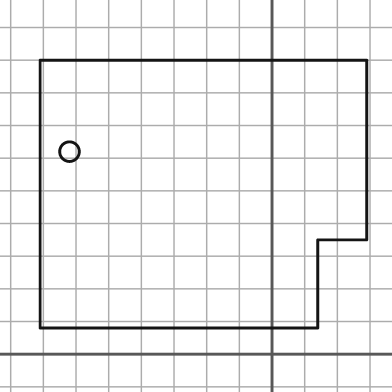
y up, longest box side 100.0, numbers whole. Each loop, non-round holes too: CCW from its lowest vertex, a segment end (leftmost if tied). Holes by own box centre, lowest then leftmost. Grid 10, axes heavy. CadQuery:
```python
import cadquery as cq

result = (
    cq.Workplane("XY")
    .moveTo(-71.0, 8.0)
    .lineTo(14.0, 8.0)
    .lineTo(14.0, 35.0)
    .lineTo(29.0, 35.0)
    .lineTo(29.0, 90.0)
    .lineTo(-71.0, 90.0)
    .close()
    .moveTo(-62.0, 62.0)
    .circle(3.0)
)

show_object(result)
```